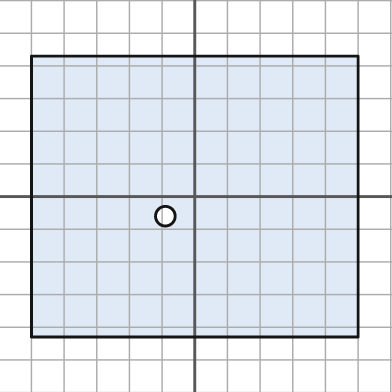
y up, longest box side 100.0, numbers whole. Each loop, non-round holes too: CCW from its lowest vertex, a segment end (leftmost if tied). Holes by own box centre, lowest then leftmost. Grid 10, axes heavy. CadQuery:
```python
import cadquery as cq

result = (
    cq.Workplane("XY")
    .moveTo(-50.0, -43.0)
    .lineTo(50.0, -43.0)
    .lineTo(50.0, 43.0)
    .lineTo(-50.0, 43.0)
    .close()
    .moveTo(-9.0, -6.0)
    .circle(3.0)
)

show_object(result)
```